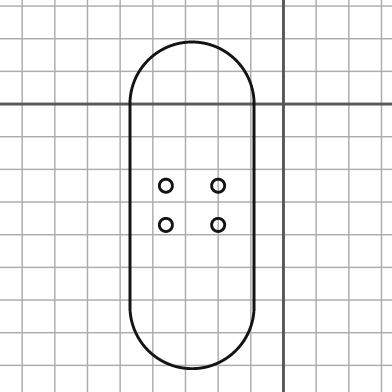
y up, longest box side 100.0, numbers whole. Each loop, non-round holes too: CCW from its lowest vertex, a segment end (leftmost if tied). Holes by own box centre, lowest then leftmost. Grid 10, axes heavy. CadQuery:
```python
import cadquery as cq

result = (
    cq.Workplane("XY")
    .moveTo(-47.0, -62.0)
    .threePointArc((-28.0, -81.0), (-9.0, -62.0))
    .lineTo(-9.0, 0.0)
    .threePointArc((-28.0, 19.0), (-47.0, 0.0))
    .close()
    .moveTo(-36.0, -37.0)
    .circle(2.0)
    .moveTo(-20.0, -37.0)
    .circle(2.0)
    .moveTo(-36.0, -25.0)
    .circle(2.0)
    .moveTo(-20.0, -25.0)
    .circle(2.0)
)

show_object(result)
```